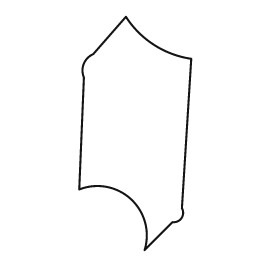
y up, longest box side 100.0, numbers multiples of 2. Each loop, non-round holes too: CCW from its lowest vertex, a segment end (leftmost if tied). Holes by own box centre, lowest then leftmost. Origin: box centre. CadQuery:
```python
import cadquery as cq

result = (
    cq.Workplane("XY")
    .moveTo(4.0, -50.0)
    .lineTo(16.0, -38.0)
    .threePointArc((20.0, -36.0), (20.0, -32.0))
    .lineTo(24.0, 32.0)
    .threePointArc((8.0, 38.0), (-4.0, 50.0))
    .lineTo(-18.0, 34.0)
    .threePointArc((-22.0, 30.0), (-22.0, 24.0))
    .lineTo(-24.0, -24.0)
    .threePointArc((-2.0, -28.0), (4.0, -50.0))
    .close()
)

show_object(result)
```